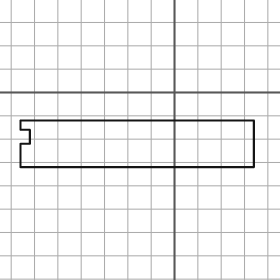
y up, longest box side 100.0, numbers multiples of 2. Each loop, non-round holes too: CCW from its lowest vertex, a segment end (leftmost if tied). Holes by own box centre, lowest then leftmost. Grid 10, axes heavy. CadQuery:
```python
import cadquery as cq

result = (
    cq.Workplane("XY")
    .moveTo(-66.0, -32.0)
    .lineTo(34.0, -32.0)
    .lineTo(34.0, -12.0)
    .lineTo(-66.0, -12.0)
    .lineTo(-66.0, -16.0)
    .lineTo(-62.0, -16.0)
    .lineTo(-62.0, -22.0)
    .lineTo(-66.0, -22.0)
    .close()
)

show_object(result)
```